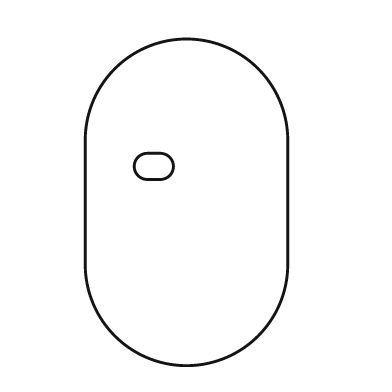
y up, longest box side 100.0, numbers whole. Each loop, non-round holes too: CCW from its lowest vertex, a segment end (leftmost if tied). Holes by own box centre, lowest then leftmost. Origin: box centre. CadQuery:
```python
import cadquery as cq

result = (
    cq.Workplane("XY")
    .moveTo(-31.0, -19.0)
    .threePointArc((0.0, -50.0), (31.0, -19.0))
    .lineTo(31.0, 19.0)
    .threePointArc((0.0, 50.0), (-31.0, 19.0))
    .close()
    .moveTo(-12.0, 7.0)
    .lineTo(-8.0, 7.0)
    .threePointArc((-4.0, 11.0), (-8.0, 15.0))
    .lineTo(-12.0, 15.0)
    .threePointArc((-16.0, 11.0), (-12.0, 7.0))
    .close()
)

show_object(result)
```